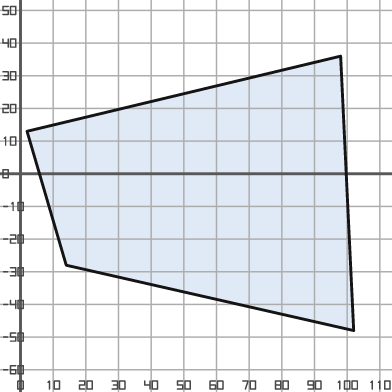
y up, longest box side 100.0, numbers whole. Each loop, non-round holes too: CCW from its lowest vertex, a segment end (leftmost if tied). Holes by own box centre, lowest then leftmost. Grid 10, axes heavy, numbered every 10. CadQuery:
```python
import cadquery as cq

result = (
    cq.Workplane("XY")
    .moveTo(102.0, -48.0)
    .lineTo(98.0, 36.0)
    .lineTo(2.0, 13.0)
    .lineTo(14.0, -28.0)
    .close()
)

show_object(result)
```